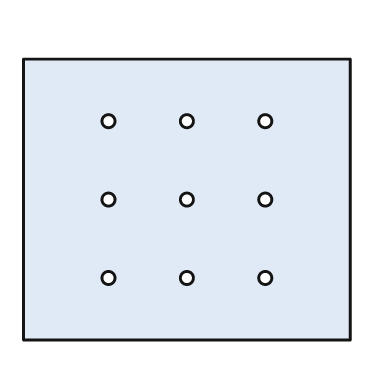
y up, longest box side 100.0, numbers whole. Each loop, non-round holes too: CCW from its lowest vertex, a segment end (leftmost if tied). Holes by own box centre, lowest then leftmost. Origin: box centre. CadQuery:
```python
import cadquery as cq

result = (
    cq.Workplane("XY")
    .moveTo(-50.0, -43.0)
    .lineTo(50.0, -43.0)
    .lineTo(50.0, 43.0)
    .lineTo(-50.0, 43.0)
    .close()
    .moveTo(-24.0, -24.0)
    .circle(2.0)
    .moveTo(0.0, -24.0)
    .circle(2.0)
    .moveTo(24.0, -24.0)
    .circle(2.0)
    .moveTo(-24.0, 0.0)
    .circle(2.0)
    .moveTo(0.0, 0.0)
    .circle(2.0)
    .moveTo(24.0, 0.0)
    .circle(2.0)
    .moveTo(-24.0, 24.0)
    .circle(2.0)
    .moveTo(0.0, 24.0)
    .circle(2.0)
    .moveTo(24.0, 24.0)
    .circle(2.0)
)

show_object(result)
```